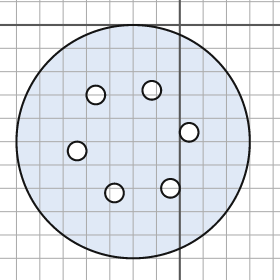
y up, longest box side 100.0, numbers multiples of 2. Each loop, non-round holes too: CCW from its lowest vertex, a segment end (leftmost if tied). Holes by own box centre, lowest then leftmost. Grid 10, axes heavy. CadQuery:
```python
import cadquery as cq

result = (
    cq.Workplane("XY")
    .moveTo(-20.0, -50.0)
    .circle(50.0)
    .moveTo(-28.0, -72.0)
    .circle(4.0)
    .moveTo(-4.0, -70.0)
    .circle(4.0)
    .moveTo(-44.0, -54.0)
    .circle(4.0)
    .moveTo(4.0, -46.0)
    .circle(4.0)
    .moveTo(-36.0, -30.0)
    .circle(4.0)
    .moveTo(-12.0, -28.0)
    .circle(4.0)
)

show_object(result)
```